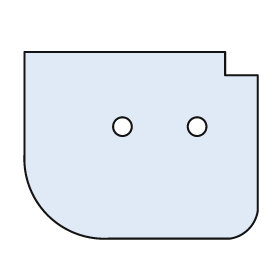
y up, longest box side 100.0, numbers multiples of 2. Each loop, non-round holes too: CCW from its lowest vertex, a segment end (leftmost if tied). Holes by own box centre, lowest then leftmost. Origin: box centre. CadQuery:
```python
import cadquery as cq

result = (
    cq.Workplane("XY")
    .moveTo(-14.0, -40.0)
    .lineTo(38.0, -40.0)
    .threePointArc((46.0, -36.0), (50.0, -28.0))
    .lineTo(50.0, 30.0)
    .lineTo(36.0, 30.0)
    .lineTo(36.0, 40.0)
    .lineTo(-50.0, 40.0)
    .lineTo(-50.0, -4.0)
    .threePointArc((-40.0, -30.0), (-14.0, -40.0))
    .close()
    .moveTo(-8.0, 8.0)
    .circle(4.0)
    .moveTo(24.0, 8.0)
    .circle(4.0)
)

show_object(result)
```